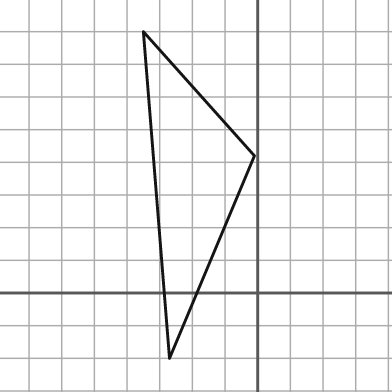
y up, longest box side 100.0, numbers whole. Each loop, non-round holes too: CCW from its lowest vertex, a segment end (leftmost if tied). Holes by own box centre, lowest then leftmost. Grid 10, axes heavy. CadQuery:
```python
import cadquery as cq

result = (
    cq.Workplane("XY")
    .moveTo(-27.0, -20.0)
    .lineTo(-1.0, 42.0)
    .lineTo(-35.0, 80.0)
    .close()
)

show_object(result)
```